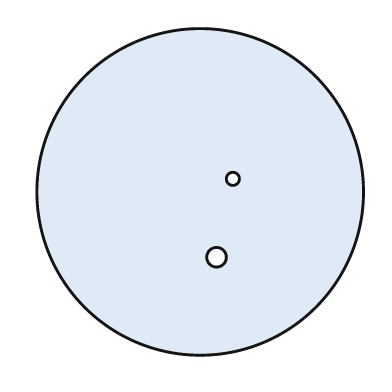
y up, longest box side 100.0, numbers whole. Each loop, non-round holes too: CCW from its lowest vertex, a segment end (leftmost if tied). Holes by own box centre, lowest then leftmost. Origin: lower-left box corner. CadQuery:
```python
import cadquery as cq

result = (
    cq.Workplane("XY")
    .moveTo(50.0, 50.0)
    .circle(50.0)
    .moveTo(55.0, 30.0)
    .circle(3.0)
    .moveTo(60.0, 54.0)
    .circle(2.0)
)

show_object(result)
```